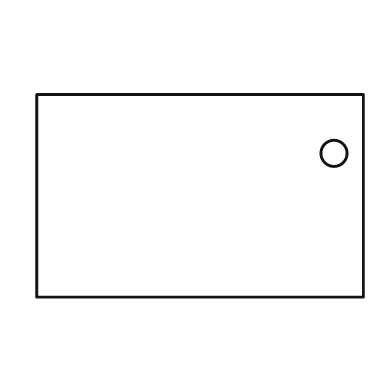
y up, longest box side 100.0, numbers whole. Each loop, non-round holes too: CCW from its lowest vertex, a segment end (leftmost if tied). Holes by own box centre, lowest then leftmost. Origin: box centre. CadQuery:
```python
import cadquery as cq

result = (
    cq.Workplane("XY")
    .moveTo(-50.0, -31.0)
    .lineTo(50.0, -31.0)
    .lineTo(50.0, 31.0)
    .lineTo(-50.0, 31.0)
    .close()
    .moveTo(41.0, 13.0)
    .circle(4.0)
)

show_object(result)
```